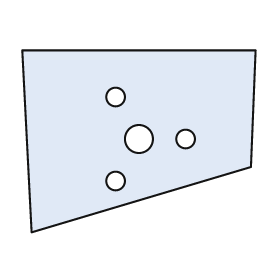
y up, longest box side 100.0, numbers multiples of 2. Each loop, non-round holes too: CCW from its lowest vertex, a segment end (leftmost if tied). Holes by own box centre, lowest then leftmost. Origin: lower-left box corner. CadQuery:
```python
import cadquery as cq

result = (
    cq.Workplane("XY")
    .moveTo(4.0, 0.0)
    .lineTo(98.0, 28.0)
    .lineTo(100.0, 78.0)
    .lineTo(0.0, 78.0)
    .close()
    .moveTo(40.0, 22.0)
    .circle(4.0)
    .moveTo(50.0, 40.0)
    .circle(6.0)
    .moveTo(70.0, 40.0)
    .circle(4.0)
    .moveTo(40.0, 58.0)
    .circle(4.0)
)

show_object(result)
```